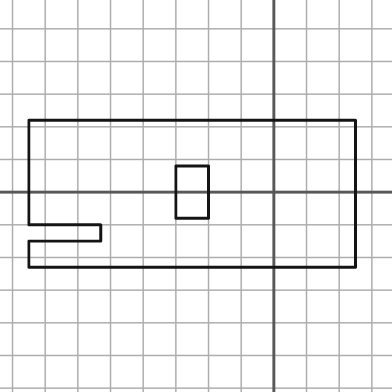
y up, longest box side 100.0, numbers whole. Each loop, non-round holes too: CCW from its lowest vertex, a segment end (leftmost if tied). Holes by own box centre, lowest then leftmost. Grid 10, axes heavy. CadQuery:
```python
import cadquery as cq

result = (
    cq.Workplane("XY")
    .moveTo(-75.0, -23.0)
    .lineTo(25.0, -23.0)
    .lineTo(25.0, 22.0)
    .lineTo(-75.0, 22.0)
    .lineTo(-75.0, -10.0)
    .lineTo(-53.0, -10.0)
    .lineTo(-53.0, -15.0)
    .lineTo(-75.0, -15.0)
    .close()
    .moveTo(-30.0, -8.0)
    .lineTo(-20.0, -8.0)
    .lineTo(-20.0, 8.0)
    .lineTo(-30.0, 8.0)
    .close()
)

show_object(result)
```